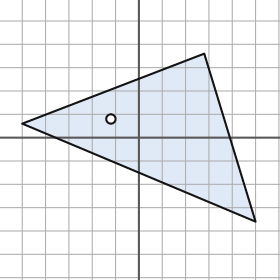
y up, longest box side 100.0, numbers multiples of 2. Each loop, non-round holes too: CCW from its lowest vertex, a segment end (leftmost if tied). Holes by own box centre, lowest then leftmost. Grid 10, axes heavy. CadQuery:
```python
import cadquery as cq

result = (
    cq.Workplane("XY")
    .moveTo(50.0, -36.0)
    .lineTo(28.0, 36.0)
    .lineTo(-50.0, 6.0)
    .close()
    .moveTo(-12.0, 8.0)
    .circle(2.0)
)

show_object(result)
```